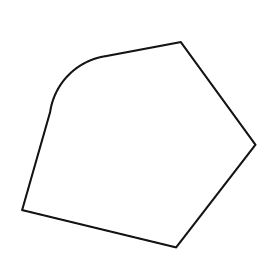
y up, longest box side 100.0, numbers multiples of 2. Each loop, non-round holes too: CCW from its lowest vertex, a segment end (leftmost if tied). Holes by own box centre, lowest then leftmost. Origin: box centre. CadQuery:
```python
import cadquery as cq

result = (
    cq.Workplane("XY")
    .moveTo(16.0, -44.0)
    .lineTo(50.0, 0.0)
    .lineTo(18.0, 44.0)
    .lineTo(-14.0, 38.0)
    .threePointArc((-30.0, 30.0), (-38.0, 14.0))
    .lineTo(-50.0, -28.0)
    .close()
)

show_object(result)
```